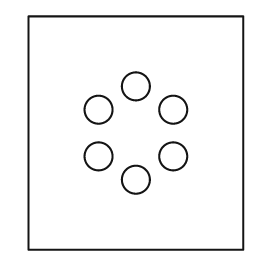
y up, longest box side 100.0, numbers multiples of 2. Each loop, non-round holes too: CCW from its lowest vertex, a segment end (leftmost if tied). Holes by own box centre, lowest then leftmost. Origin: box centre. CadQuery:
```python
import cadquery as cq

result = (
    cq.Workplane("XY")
    .moveTo(-46.0, -50.0)
    .lineTo(46.0, -50.0)
    .lineTo(46.0, 50.0)
    .lineTo(-46.0, 50.0)
    .close()
    .moveTo(0.0, -20.0)
    .circle(6.0)
    .moveTo(-16.0, -10.0)
    .circle(6.0)
    .moveTo(16.0, -10.0)
    .circle(6.0)
    .moveTo(-16.0, 10.0)
    .circle(6.0)
    .moveTo(16.0, 10.0)
    .circle(6.0)
    .moveTo(0.0, 20.0)
    .circle(6.0)
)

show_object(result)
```